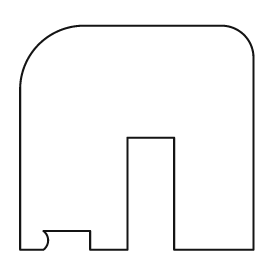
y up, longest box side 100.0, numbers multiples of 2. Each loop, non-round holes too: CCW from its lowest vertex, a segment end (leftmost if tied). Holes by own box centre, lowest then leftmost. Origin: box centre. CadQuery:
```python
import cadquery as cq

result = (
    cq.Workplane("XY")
    .moveTo(-50.0, -48.0)
    .lineTo(-40.0, -48.0)
    .threePointArc((-38.0, -44.0), (-40.0, -40.0))
    .lineTo(-20.0, -40.0)
    .lineTo(-20.0, -48.0)
    .lineTo(-4.0, -48.0)
    .lineTo(-4.0, 0.0)
    .lineTo(16.0, 0.0)
    .lineTo(16.0, -48.0)
    .lineTo(50.0, -48.0)
    .lineTo(50.0, 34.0)
    .threePointArc((46.0, 44.0), (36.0, 48.0))
    .lineTo(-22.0, 48.0)
    .threePointArc((-42.0, 40.0), (-50.0, 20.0))
    .close()
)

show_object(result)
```